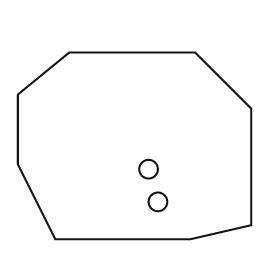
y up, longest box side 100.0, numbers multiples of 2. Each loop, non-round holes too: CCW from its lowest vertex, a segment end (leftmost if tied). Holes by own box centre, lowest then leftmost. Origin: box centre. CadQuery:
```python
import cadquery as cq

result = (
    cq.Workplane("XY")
    .moveTo(-34.0, -40.0)
    .lineTo(24.0, -40.0)
    .lineTo(50.0, -34.0)
    .lineTo(50.0, 16.0)
    .lineTo(26.0, 40.0)
    .lineTo(-28.0, 40.0)
    .lineTo(-50.0, 22.0)
    .lineTo(-50.0, -8.0)
    .close()
    .moveTo(10.0, -24.0)
    .circle(4.0)
    .moveTo(6.0, -10.0)
    .circle(4.0)
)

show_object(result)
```